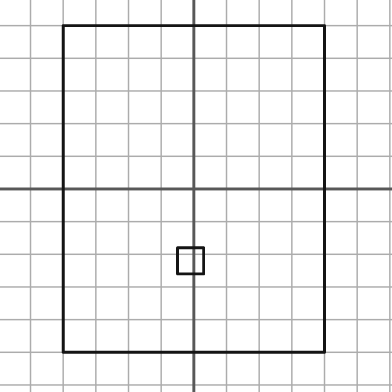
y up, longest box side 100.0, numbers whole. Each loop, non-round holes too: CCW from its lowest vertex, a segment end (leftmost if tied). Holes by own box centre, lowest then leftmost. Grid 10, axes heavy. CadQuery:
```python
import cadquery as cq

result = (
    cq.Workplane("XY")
    .moveTo(-40.0, -50.0)
    .lineTo(40.0, -50.0)
    .lineTo(40.0, 50.0)
    .lineTo(-40.0, 50.0)
    .close()
    .moveTo(-5.0, -26.0)
    .lineTo(3.0, -26.0)
    .lineTo(3.0, -18.0)
    .lineTo(-5.0, -18.0)
    .close()
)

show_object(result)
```